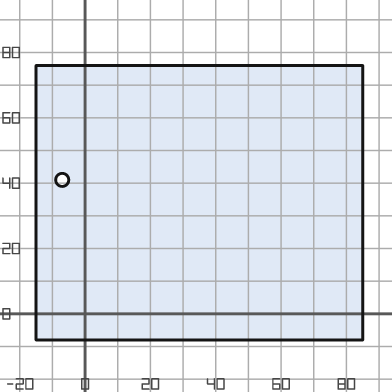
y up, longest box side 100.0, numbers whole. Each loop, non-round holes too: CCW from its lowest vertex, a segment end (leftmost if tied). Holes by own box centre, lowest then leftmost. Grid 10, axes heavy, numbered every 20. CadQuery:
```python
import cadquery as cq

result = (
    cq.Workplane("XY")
    .moveTo(-15.0, -8.0)
    .lineTo(85.0, -8.0)
    .lineTo(85.0, 76.0)
    .lineTo(-15.0, 76.0)
    .close()
    .moveTo(-7.0, 41.0)
    .circle(2.0)
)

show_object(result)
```